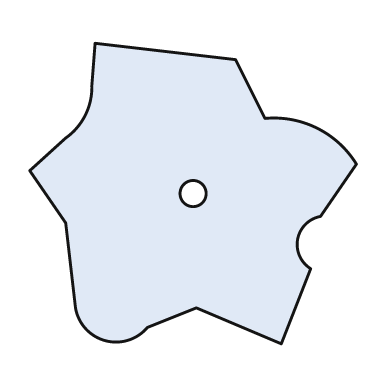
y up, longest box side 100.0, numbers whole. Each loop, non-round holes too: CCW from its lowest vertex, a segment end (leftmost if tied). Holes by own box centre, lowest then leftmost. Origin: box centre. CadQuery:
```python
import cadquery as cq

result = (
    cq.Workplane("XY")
    .moveTo(27.0, -46.0)
    .lineTo(36.0, -23.0)
    .threePointArc((32.0, -14.0), (39.0, -7.0))
    .lineTo(50.0, 9.0)
    .threePointArc((38.0, 20.0), (22.0, 23.0))
    .lineTo(13.0, 41.0)
    .lineTo(-30.0, 46.0)
    .lineTo(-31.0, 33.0)
    .threePointArc((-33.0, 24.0), (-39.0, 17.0))
    .lineTo(-50.0, 7.0)
    .lineTo(-39.0, -9.0)
    .lineTo(-36.0, -35.0)
    .threePointArc((-27.0, -45.0), (-14.0, -41.0))
    .lineTo(1.0, -35.0)
    .close()
    .moveTo(0.0, 0.0)
    .circle(4.0)
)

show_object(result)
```